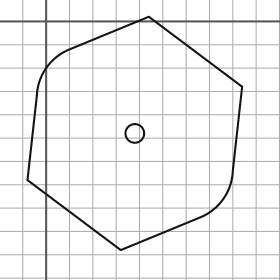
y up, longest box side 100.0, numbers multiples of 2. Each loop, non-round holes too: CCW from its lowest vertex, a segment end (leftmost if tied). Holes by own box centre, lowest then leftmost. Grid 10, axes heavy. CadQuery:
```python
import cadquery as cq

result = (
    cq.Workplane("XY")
    .moveTo(32.0, -98.0)
    .lineTo(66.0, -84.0)
    .threePointArc((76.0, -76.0), (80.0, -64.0))
    .lineTo(84.0, -28.0)
    .lineTo(44.0, 2.0)
    .lineTo(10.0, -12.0)
    .threePointArc((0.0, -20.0), (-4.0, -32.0))
    .lineTo(-8.0, -68.0)
    .close()
    .moveTo(38.0, -48.0)
    .circle(4.0)
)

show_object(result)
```